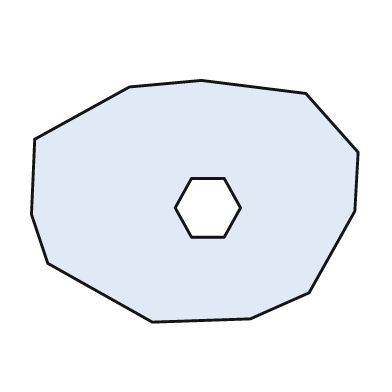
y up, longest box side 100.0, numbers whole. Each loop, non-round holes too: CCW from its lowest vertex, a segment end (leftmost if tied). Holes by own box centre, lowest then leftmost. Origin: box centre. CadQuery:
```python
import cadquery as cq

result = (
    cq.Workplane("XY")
    .moveTo(-13.0, -37.0)
    .lineTo(17.0, -36.0)
    .lineTo(35.0, -28.0)
    .lineTo(49.0, -3.0)
    .lineTo(50.0, 15.0)
    .lineTo(34.0, 33.0)
    .lineTo(2.0, 37.0)
    .lineTo(-20.0, 35.0)
    .lineTo(-49.0, 19.0)
    .lineTo(-50.0, -4.0)
    .lineTo(-45.0, -19.0)
    .close()
    .moveTo(-1.0, -11.0)
    .lineTo(9.0, -11.0)
    .lineTo(14.0, -2.0)
    .lineTo(9.0, 7.0)
    .lineTo(-1.0, 7.0)
    .lineTo(-6.0, -2.0)
    .close()
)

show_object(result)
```